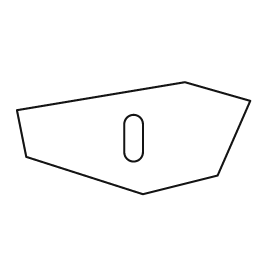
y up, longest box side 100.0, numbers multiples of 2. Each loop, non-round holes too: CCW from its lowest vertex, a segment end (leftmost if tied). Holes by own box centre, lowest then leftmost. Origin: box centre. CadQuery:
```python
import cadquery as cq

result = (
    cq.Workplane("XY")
    .moveTo(4.0, -24.0)
    .lineTo(36.0, -16.0)
    .lineTo(50.0, 16.0)
    .lineTo(22.0, 24.0)
    .lineTo(-50.0, 12.0)
    .lineTo(-46.0, -8.0)
    .close()
    .moveTo(-4.0, -6.0)
    .threePointArc((0.0, -10.0), (4.0, -6.0))
    .lineTo(4.0, 6.0)
    .threePointArc((0.0, 10.0), (-4.0, 6.0))
    .close()
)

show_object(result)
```